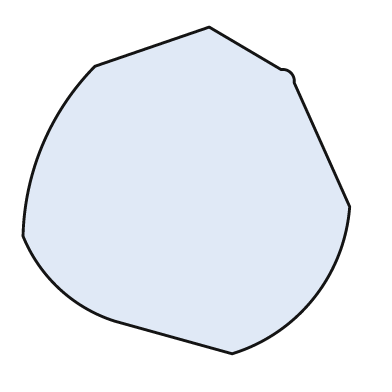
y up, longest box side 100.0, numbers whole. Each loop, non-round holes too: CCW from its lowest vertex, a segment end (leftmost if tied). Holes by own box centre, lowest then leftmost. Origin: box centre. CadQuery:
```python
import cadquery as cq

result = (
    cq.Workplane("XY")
    .moveTo(14.0, -50.0)
    .threePointArc((39.0, -33.0), (50.0, -5.0))
    .lineTo(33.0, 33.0)
    .threePointArc((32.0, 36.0), (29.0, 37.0))
    .lineTo(7.0, 50.0)
    .lineTo(-28.0, 38.0)
    .threePointArc((-44.0, 14.0), (-50.0, -14.0))
    .threePointArc((-39.0, -30.0), (-22.0, -40.0))
    .close()
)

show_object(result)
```